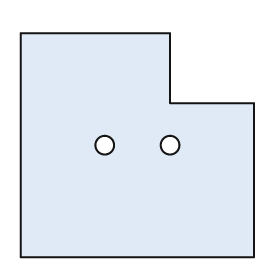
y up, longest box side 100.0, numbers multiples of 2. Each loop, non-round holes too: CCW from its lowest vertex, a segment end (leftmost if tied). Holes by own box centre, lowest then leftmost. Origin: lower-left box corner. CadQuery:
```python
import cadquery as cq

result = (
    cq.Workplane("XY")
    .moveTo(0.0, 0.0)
    .lineTo(100.0, 0.0)
    .lineTo(100.0, 66.0)
    .lineTo(64.0, 66.0)
    .lineTo(64.0, 96.0)
    .lineTo(0.0, 96.0)
    .close()
    .moveTo(36.0, 48.0)
    .circle(4.0)
    .moveTo(64.0, 48.0)
    .circle(4.0)
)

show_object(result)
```